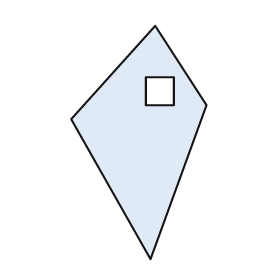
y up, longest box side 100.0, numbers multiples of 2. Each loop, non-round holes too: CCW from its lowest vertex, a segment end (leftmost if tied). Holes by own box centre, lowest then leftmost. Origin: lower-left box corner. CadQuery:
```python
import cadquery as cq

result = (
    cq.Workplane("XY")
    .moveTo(34.0, 0.0)
    .lineTo(58.0, 66.0)
    .lineTo(36.0, 100.0)
    .lineTo(0.0, 60.0)
    .close()
    .moveTo(32.0, 66.0)
    .lineTo(44.0, 66.0)
    .lineTo(44.0, 78.0)
    .lineTo(32.0, 78.0)
    .close()
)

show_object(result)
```